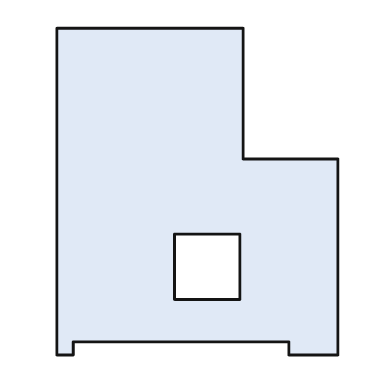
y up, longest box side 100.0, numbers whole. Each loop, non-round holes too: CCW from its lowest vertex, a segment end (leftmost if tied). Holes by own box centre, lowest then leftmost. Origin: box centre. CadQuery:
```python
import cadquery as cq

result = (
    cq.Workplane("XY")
    .moveTo(-43.0, -50.0)
    .lineTo(-38.0, -50.0)
    .lineTo(-38.0, -46.0)
    .lineTo(28.0, -46.0)
    .lineTo(28.0, -50.0)
    .lineTo(43.0, -50.0)
    .lineTo(43.0, 10.0)
    .lineTo(14.0, 10.0)
    .lineTo(14.0, 50.0)
    .lineTo(-43.0, 50.0)
    .close()
    .moveTo(-7.0, -33.0)
    .lineTo(13.0, -33.0)
    .lineTo(13.0, -13.0)
    .lineTo(-7.0, -13.0)
    .close()
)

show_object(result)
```